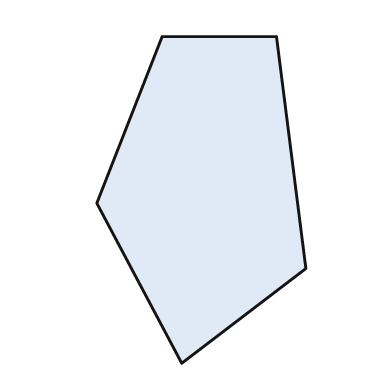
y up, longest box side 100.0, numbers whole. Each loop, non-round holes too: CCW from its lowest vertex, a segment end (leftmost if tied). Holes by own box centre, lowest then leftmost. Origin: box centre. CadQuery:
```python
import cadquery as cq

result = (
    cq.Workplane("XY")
    .moveTo(-6.0, -50.0)
    .lineTo(32.0, -21.0)
    .lineTo(23.0, 50.0)
    .lineTo(-12.0, 50.0)
    .lineTo(-32.0, -1.0)
    .close()
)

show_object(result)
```